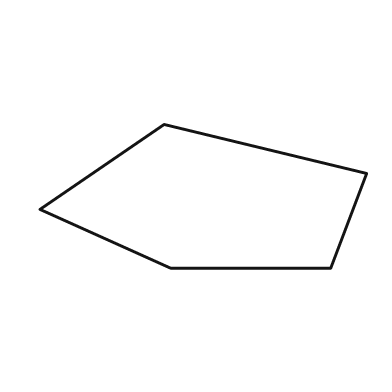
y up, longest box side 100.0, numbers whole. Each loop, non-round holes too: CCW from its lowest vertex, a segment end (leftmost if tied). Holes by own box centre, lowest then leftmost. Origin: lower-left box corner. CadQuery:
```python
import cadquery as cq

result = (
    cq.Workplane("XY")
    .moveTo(40.0, 0.0)
    .lineTo(89.0, 0.0)
    .lineTo(100.0, 29.0)
    .lineTo(38.0, 44.0)
    .lineTo(0.0, 18.0)
    .close()
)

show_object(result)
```